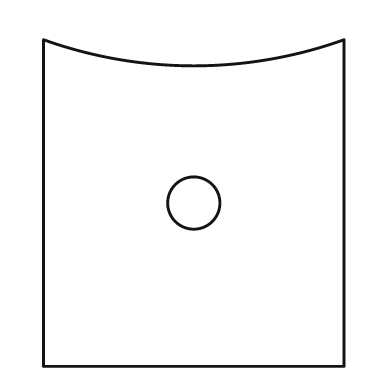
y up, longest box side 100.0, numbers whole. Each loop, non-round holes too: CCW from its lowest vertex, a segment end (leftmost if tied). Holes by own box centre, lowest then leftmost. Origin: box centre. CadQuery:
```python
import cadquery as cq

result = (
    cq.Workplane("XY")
    .moveTo(-46.0, -50.0)
    .lineTo(46.0, -50.0)
    .lineTo(46.0, 50.0)
    .threePointArc((0.0, 42.0), (-46.0, 50.0))
    .close()
    .moveTo(0.0, 0.0)
    .circle(8.0)
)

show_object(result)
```